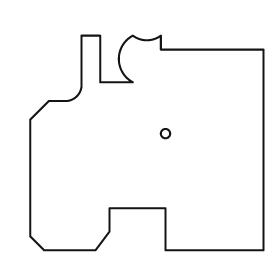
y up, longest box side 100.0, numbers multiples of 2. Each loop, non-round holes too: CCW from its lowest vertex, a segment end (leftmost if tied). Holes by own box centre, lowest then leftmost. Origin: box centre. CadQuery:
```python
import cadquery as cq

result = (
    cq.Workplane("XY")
    .moveTo(-44.0, -46.0)
    .lineTo(-22.0, -46.0)
    .lineTo(-16.0, -38.0)
    .lineTo(-16.0, -28.0)
    .lineTo(8.0, -28.0)
    .lineTo(8.0, -46.0)
    .lineTo(50.0, -46.0)
    .lineTo(50.0, 40.0)
    .lineTo(6.0, 40.0)
    .lineTo(6.0, 46.0)
    .threePointArc((0.0, 44.0), (-6.0, 46.0))
    .threePointArc((-12.0, 36.0), (-6.0, 26.0))
    .lineTo(-20.0, 26.0)
    .lineTo(-20.0, 46.0)
    .lineTo(-28.0, 46.0)
    .lineTo(-28.0, 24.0)
    .threePointArc((-30.0, 20.0), (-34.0, 18.0))
    .lineTo(-42.0, 18.0)
    .lineTo(-50.0, 10.0)
    .lineTo(-50.0, -40.0)
    .close()
    .moveTo(8.0, 4.0)
    .circle(2.0)
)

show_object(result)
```